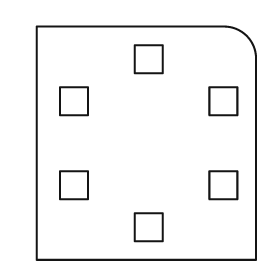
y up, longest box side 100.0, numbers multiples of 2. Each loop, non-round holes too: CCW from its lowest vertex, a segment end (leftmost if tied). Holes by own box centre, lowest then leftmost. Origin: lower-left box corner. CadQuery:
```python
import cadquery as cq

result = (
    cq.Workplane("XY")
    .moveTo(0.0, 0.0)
    .lineTo(94.0, 0.0)
    .lineTo(94.0, 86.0)
    .threePointArc((90.0, 96.0), (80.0, 100.0))
    .lineTo(0.0, 100.0)
    .close()
    .moveTo(42.0, 8.0)
    .lineTo(54.0, 8.0)
    .lineTo(54.0, 20.0)
    .lineTo(42.0, 20.0)
    .close()
    .moveTo(10.0, 26.0)
    .lineTo(22.0, 26.0)
    .lineTo(22.0, 38.0)
    .lineTo(10.0, 38.0)
    .close()
    .moveTo(74.0, 26.0)
    .lineTo(86.0, 26.0)
    .lineTo(86.0, 38.0)
    .lineTo(74.0, 38.0)
    .close()
    .moveTo(10.0, 62.0)
    .lineTo(22.0, 62.0)
    .lineTo(22.0, 74.0)
    .lineTo(10.0, 74.0)
    .close()
    .moveTo(74.0, 62.0)
    .lineTo(86.0, 62.0)
    .lineTo(86.0, 74.0)
    .lineTo(74.0, 74.0)
    .close()
    .moveTo(42.0, 80.0)
    .lineTo(54.0, 80.0)
    .lineTo(54.0, 92.0)
    .lineTo(42.0, 92.0)
    .close()
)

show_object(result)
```